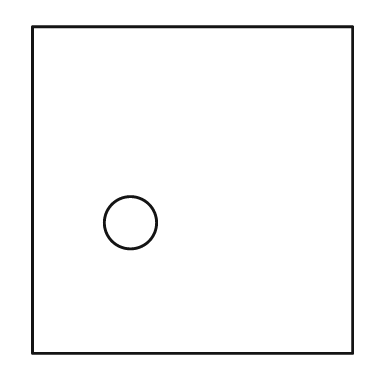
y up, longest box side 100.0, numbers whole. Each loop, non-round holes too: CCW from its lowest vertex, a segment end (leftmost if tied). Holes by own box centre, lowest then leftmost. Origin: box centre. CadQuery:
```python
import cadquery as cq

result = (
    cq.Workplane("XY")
    .moveTo(-49.0, -50.0)
    .lineTo(49.0, -50.0)
    .lineTo(49.0, 50.0)
    .lineTo(-49.0, 50.0)
    .close()
    .moveTo(-19.0, -10.0)
    .circle(8.0)
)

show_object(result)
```